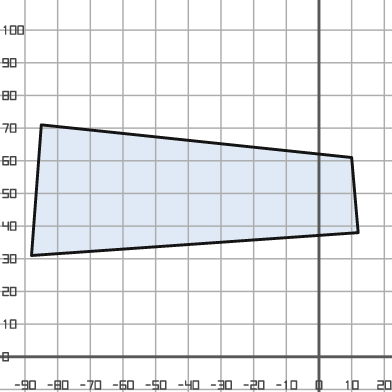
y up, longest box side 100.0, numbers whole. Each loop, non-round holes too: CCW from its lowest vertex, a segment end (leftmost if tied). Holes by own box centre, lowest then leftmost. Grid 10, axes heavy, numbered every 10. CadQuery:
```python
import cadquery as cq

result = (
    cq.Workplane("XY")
    .moveTo(-88.0, 31.0)
    .lineTo(12.0, 38.0)
    .lineTo(10.0, 61.0)
    .lineTo(-85.0, 71.0)
    .close()
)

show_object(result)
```